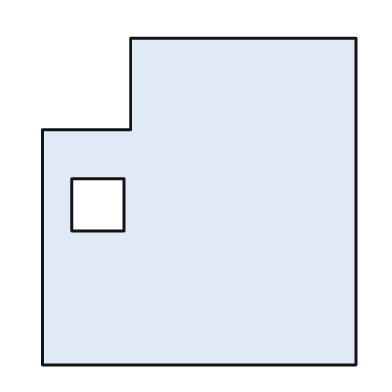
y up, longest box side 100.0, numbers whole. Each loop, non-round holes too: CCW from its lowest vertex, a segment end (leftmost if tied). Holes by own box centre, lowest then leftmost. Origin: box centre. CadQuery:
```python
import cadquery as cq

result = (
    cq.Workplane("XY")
    .moveTo(-48.0, -50.0)
    .lineTo(48.0, -50.0)
    .lineTo(48.0, 50.0)
    .lineTo(-21.0, 50.0)
    .lineTo(-21.0, 22.0)
    .lineTo(-48.0, 22.0)
    .close()
    .moveTo(-39.0, -9.0)
    .lineTo(-23.0, -9.0)
    .lineTo(-23.0, 7.0)
    .lineTo(-39.0, 7.0)
    .close()
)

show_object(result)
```